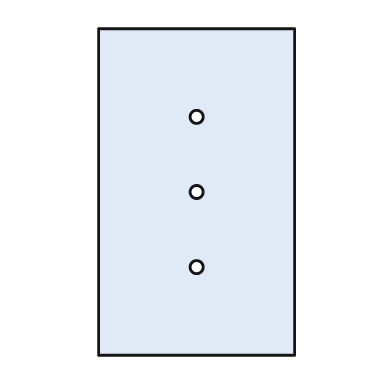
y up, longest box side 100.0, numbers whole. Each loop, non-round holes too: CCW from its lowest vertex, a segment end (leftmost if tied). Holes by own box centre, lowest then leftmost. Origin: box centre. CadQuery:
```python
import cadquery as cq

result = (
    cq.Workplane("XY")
    .moveTo(-30.0, -50.0)
    .lineTo(30.0, -50.0)
    .lineTo(30.0, 50.0)
    .lineTo(-30.0, 50.0)
    .close()
    .moveTo(0.0, -23.0)
    .circle(2.0)
    .moveTo(0.0, 0.0)
    .circle(2.0)
    .moveTo(0.0, 23.0)
    .circle(2.0)
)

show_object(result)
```